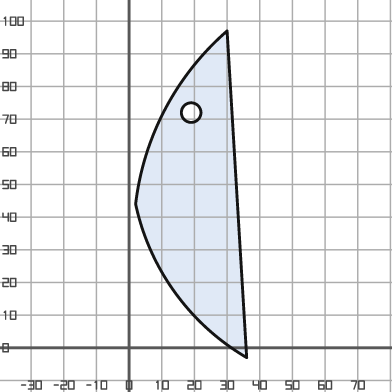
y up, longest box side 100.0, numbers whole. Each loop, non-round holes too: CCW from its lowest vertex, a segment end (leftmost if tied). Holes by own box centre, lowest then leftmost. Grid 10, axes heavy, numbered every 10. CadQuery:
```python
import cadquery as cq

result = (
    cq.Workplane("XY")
    .moveTo(36.0, -3.0)
    .lineTo(30.0, 97.0)
    .threePointArc((11.0, 73.0), (2.0, 44.0))
    .threePointArc((14.0, 17.0), (36.0, -3.0))
    .close()
    .moveTo(19.0, 72.0)
    .circle(3.0)
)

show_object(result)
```